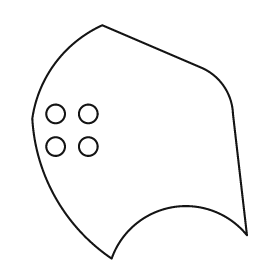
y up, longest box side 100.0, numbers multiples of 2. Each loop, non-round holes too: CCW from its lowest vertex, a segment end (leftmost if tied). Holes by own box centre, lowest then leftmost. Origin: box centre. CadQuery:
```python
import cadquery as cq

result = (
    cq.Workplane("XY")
    .moveTo(-12.0, -50.0)
    .threePointArc((14.0, -28.0), (46.0, -40.0))
    .lineTo(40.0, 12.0)
    .threePointArc((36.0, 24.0), (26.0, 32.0))
    .lineTo(-16.0, 50.0)
    .threePointArc((-36.0, 34.0), (-46.0, 10.0))
    .threePointArc((-36.0, -24.0), (-12.0, -50.0))
    .close()
    .moveTo(-36.0, -2.0)
    .circle(4.0)
    .moveTo(-22.0, -2.0)
    .circle(4.0)
    .moveTo(-36.0, 12.0)
    .circle(4.0)
    .moveTo(-22.0, 12.0)
    .circle(4.0)
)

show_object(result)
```